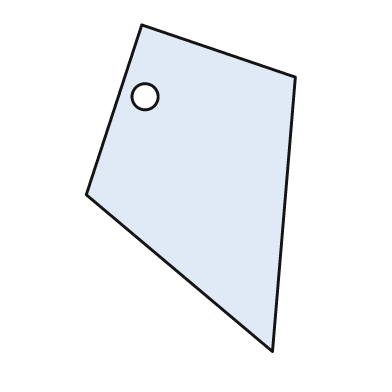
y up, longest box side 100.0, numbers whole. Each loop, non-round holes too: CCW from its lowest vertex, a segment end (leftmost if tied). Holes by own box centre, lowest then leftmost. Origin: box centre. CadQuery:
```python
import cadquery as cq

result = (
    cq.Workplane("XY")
    .moveTo(25.0, -50.0)
    .lineTo(32.0, 34.0)
    .lineTo(-15.0, 50.0)
    .lineTo(-32.0, -2.0)
    .close()
    .moveTo(-14.0, 28.0)
    .circle(4.0)
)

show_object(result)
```